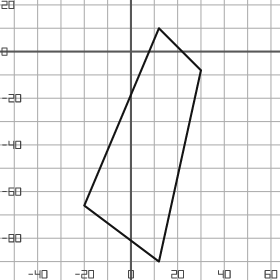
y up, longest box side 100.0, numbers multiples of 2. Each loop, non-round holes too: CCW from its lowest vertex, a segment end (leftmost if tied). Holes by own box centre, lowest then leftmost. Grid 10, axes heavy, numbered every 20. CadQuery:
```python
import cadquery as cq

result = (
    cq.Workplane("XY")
    .moveTo(12.0, -90.0)
    .lineTo(30.0, -8.0)
    .lineTo(12.0, 10.0)
    .lineTo(-20.0, -66.0)
    .close()
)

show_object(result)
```